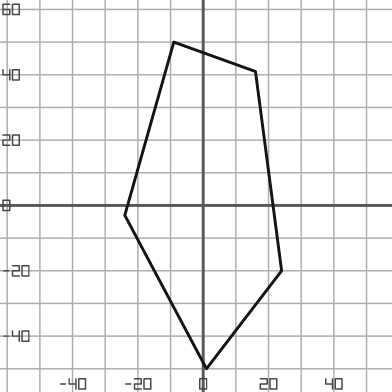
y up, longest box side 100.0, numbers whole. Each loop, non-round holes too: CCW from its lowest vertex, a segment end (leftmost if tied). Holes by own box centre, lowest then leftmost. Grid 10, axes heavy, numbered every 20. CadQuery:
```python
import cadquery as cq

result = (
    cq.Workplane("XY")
    .moveTo(1.0, -50.0)
    .lineTo(24.0, -20.0)
    .lineTo(16.0, 41.0)
    .lineTo(-9.0, 50.0)
    .lineTo(-24.0, -3.0)
    .close()
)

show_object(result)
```